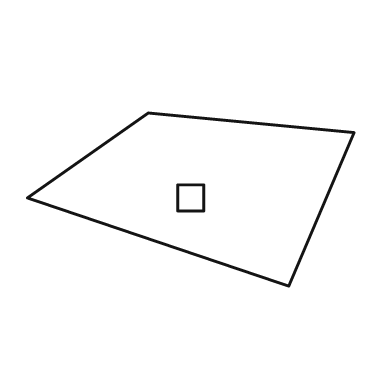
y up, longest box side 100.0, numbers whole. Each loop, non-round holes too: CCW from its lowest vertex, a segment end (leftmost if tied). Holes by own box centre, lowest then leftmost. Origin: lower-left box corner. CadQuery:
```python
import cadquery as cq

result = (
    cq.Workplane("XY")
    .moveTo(80.0, 0.0)
    .lineTo(100.0, 47.0)
    .lineTo(37.0, 53.0)
    .lineTo(0.0, 27.0)
    .close()
    .moveTo(46.0, 23.0)
    .lineTo(54.0, 23.0)
    .lineTo(54.0, 31.0)
    .lineTo(46.0, 31.0)
    .close()
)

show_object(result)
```